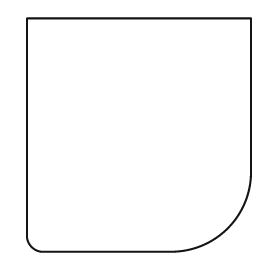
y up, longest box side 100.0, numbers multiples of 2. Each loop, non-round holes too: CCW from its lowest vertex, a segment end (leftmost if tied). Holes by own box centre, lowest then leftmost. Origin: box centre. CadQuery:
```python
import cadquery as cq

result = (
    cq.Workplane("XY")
    .moveTo(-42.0, -50.0)
    .lineTo(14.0, -50.0)
    .threePointArc((38.0, -40.0), (48.0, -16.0))
    .lineTo(48.0, 50.0)
    .lineTo(-48.0, 50.0)
    .lineTo(-48.0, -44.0)
    .threePointArc((-46.0, -48.0), (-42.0, -50.0))
    .close()
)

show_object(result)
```